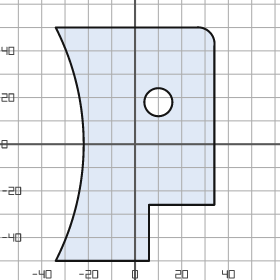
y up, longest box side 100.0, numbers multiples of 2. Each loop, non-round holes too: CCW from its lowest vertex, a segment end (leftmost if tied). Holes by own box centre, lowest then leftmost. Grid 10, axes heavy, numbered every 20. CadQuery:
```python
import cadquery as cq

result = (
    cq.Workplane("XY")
    .moveTo(-34.0, -50.0)
    .lineTo(6.0, -50.0)
    .lineTo(6.0, -26.0)
    .lineTo(34.0, -26.0)
    .lineTo(34.0, 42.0)
    .threePointArc((32.0, 48.0), (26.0, 50.0))
    .lineTo(-34.0, 50.0)
    .threePointArc((-22.0, 0.0), (-34.0, -50.0))
    .close()
    .moveTo(10.0, 18.0)
    .circle(6.0)
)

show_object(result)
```